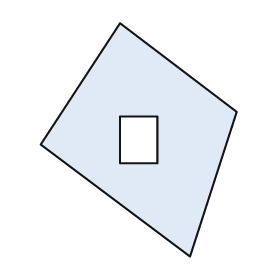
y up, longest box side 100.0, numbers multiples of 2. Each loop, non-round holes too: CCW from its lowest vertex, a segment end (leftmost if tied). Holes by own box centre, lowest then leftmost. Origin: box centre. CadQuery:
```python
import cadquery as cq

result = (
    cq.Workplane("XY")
    .moveTo(22.0, -50.0)
    .lineTo(42.0, 12.0)
    .lineTo(-8.0, 50.0)
    .lineTo(-42.0, -2.0)
    .close()
    .moveTo(-8.0, -10.0)
    .lineTo(8.0, -10.0)
    .lineTo(8.0, 10.0)
    .lineTo(-8.0, 10.0)
    .close()
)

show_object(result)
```